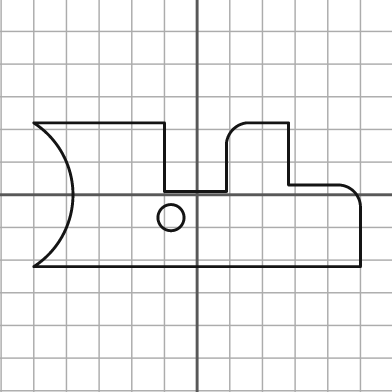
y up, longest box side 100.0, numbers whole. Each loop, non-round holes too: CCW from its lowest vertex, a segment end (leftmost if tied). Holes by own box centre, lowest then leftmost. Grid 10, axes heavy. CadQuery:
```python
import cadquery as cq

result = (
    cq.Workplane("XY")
    .moveTo(-50.0, -22.0)
    .lineTo(50.0, -22.0)
    .lineTo(50.0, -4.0)
    .threePointArc((48.0, 1.0), (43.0, 3.0))
    .lineTo(28.0, 3.0)
    .lineTo(28.0, 22.0)
    .lineTo(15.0, 22.0)
    .threePointArc((11.0, 20.0), (9.0, 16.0))
    .lineTo(9.0, 1.0)
    .lineTo(-10.0, 1.0)
    .lineTo(-10.0, 22.0)
    .lineTo(-50.0, 22.0)
    .threePointArc((-38.0, 0.0), (-50.0, -22.0))
    .close()
    .moveTo(-8.0, -7.0)
    .circle(4.0)
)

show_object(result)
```